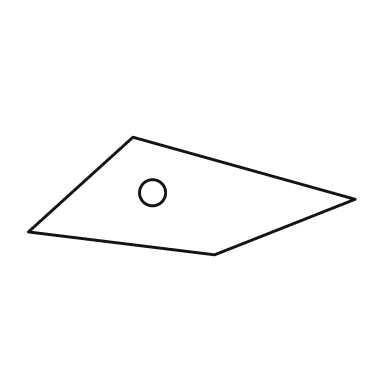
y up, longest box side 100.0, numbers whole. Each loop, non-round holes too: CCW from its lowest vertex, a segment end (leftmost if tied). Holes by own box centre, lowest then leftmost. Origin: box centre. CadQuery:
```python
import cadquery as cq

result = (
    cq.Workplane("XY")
    .moveTo(7.0, -18.0)
    .lineTo(50.0, -1.0)
    .lineTo(-18.0, 18.0)
    .lineTo(-50.0, -11.0)
    .close()
    .moveTo(-12.0, 1.0)
    .circle(4.0)
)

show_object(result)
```